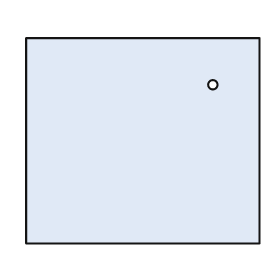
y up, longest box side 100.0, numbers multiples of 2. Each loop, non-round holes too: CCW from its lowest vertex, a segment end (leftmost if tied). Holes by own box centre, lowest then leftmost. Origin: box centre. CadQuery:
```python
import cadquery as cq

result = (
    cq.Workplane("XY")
    .moveTo(-50.0, -44.0)
    .lineTo(50.0, -44.0)
    .lineTo(50.0, 44.0)
    .lineTo(-50.0, 44.0)
    .close()
    .moveTo(30.0, 24.0)
    .circle(2.0)
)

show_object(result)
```